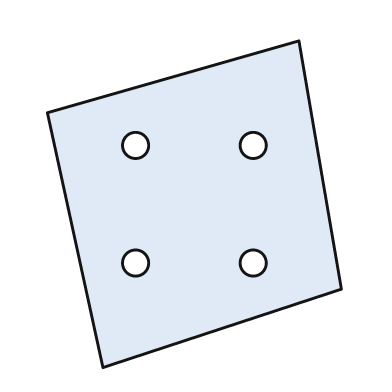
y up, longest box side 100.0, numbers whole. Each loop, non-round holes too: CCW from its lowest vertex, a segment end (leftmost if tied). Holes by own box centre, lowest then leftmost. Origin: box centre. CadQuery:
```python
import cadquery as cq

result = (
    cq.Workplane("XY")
    .moveTo(-28.0, -50.0)
    .lineTo(45.0, -26.0)
    .lineTo(32.0, 50.0)
    .lineTo(-45.0, 28.0)
    .close()
    .moveTo(-18.0, -18.0)
    .circle(4.0)
    .moveTo(18.0, -18.0)
    .circle(4.0)
    .moveTo(-18.0, 18.0)
    .circle(4.0)
    .moveTo(18.0, 18.0)
    .circle(4.0)
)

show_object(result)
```